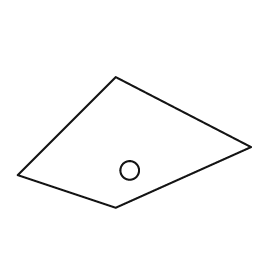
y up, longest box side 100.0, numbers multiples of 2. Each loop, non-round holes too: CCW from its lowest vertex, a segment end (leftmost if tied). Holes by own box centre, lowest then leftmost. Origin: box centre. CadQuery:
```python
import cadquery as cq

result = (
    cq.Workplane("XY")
    .moveTo(-8.0, -28.0)
    .lineTo(50.0, -2.0)
    .lineTo(-8.0, 28.0)
    .lineTo(-50.0, -14.0)
    .close()
    .moveTo(-2.0, -12.0)
    .circle(4.0)
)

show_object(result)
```